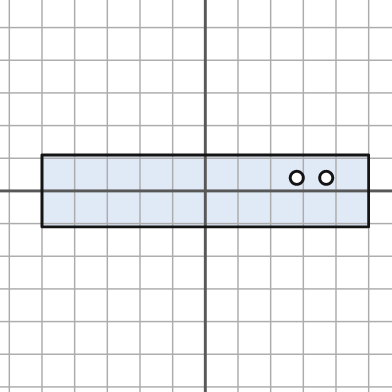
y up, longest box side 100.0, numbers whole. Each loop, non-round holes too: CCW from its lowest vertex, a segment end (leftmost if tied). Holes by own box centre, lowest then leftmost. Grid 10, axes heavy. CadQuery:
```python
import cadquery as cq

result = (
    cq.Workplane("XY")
    .moveTo(-50.0, -11.0)
    .lineTo(50.0, -11.0)
    .lineTo(50.0, 11.0)
    .lineTo(-50.0, 11.0)
    .close()
    .moveTo(28.0, 4.0)
    .circle(2.0)
    .moveTo(37.0, 4.0)
    .circle(2.0)
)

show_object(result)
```